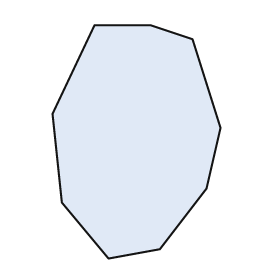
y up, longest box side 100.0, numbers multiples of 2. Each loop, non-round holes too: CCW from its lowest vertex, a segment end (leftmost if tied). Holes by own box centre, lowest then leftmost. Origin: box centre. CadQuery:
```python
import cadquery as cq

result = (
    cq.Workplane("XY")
    .moveTo(-12.0, -50.0)
    .lineTo(10.0, -46.0)
    .lineTo(30.0, -20.0)
    .lineTo(36.0, 6.0)
    .lineTo(24.0, 44.0)
    .lineTo(6.0, 50.0)
    .lineTo(-18.0, 50.0)
    .lineTo(-36.0, 12.0)
    .lineTo(-32.0, -26.0)
    .close()
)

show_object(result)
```